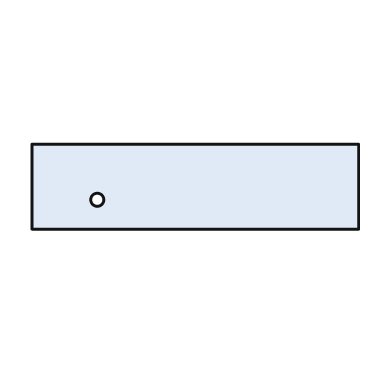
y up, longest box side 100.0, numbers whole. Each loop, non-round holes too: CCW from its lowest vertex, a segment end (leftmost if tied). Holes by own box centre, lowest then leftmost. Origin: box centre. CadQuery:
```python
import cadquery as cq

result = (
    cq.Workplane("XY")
    .moveTo(-50.0, -13.0)
    .lineTo(50.0, -13.0)
    .lineTo(50.0, 13.0)
    .lineTo(-50.0, 13.0)
    .close()
    .moveTo(-30.0, -4.0)
    .circle(2.0)
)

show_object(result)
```